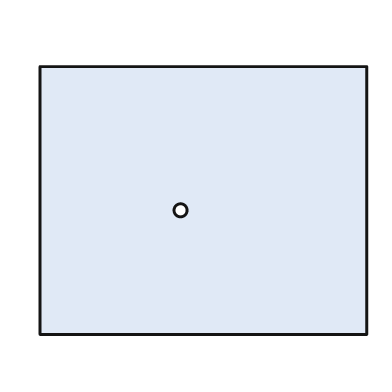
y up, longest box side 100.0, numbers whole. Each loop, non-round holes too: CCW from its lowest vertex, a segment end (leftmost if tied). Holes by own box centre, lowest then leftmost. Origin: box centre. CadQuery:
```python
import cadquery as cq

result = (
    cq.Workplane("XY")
    .moveTo(-50.0, -41.0)
    .lineTo(50.0, -41.0)
    .lineTo(50.0, 41.0)
    .lineTo(-50.0, 41.0)
    .close()
    .moveTo(-7.0, -3.0)
    .circle(2.0)
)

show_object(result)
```